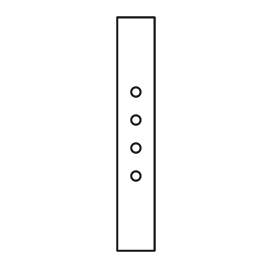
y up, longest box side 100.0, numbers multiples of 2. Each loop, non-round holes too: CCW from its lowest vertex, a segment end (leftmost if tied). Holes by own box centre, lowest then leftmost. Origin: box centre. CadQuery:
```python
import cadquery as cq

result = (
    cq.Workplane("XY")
    .moveTo(-8.0, -50.0)
    .lineTo(8.0, -50.0)
    .lineTo(8.0, 50.0)
    .lineTo(-8.0, 50.0)
    .close()
    .moveTo(0.0, -18.0)
    .circle(2.0)
    .moveTo(0.0, -6.0)
    .circle(2.0)
    .moveTo(0.0, 6.0)
    .circle(2.0)
    .moveTo(0.0, 18.0)
    .circle(2.0)
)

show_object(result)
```